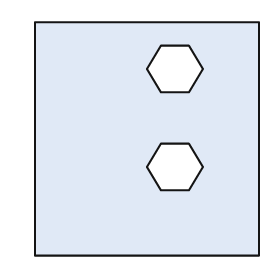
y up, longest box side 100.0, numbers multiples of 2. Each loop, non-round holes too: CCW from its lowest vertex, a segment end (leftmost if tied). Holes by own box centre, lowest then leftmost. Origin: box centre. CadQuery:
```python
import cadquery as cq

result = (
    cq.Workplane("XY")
    .moveTo(-48.0, -50.0)
    .lineTo(48.0, -50.0)
    .lineTo(48.0, 50.0)
    .lineTo(-48.0, 50.0)
    .close()
    .moveTo(6.0, -22.0)
    .lineTo(18.0, -22.0)
    .lineTo(24.0, -12.0)
    .lineTo(18.0, -2.0)
    .lineTo(6.0, -2.0)
    .lineTo(0.0, -12.0)
    .close()
    .moveTo(6.0, 20.0)
    .lineTo(18.0, 20.0)
    .lineTo(24.0, 30.0)
    .lineTo(18.0, 40.0)
    .lineTo(6.0, 40.0)
    .lineTo(0.0, 30.0)
    .close()
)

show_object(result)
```